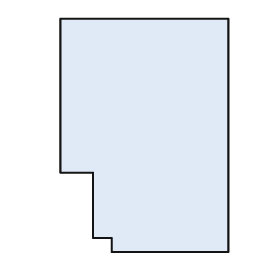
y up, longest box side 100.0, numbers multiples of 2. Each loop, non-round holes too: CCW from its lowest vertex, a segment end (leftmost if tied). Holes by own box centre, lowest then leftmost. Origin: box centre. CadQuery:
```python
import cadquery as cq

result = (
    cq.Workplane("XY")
    .moveTo(-14.0, -50.0)
    .lineTo(36.0, -50.0)
    .lineTo(36.0, 50.0)
    .lineTo(-36.0, 50.0)
    .lineTo(-36.0, -16.0)
    .lineTo(-22.0, -16.0)
    .lineTo(-22.0, -44.0)
    .lineTo(-14.0, -44.0)
    .close()
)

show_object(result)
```